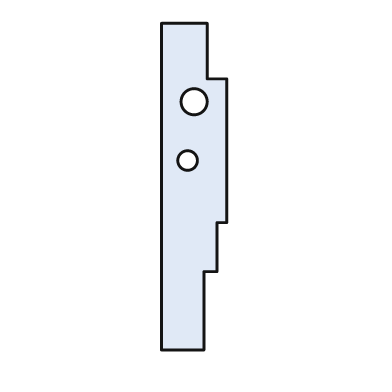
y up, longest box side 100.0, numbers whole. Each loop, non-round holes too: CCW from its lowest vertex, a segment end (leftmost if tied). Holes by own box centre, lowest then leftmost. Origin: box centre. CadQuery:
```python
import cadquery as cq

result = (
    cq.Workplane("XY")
    .moveTo(-10.0, -50.0)
    .lineTo(3.0, -50.0)
    .lineTo(3.0, -26.0)
    .lineTo(7.0, -26.0)
    .lineTo(7.0, -11.0)
    .lineTo(10.0, -11.0)
    .lineTo(10.0, 33.0)
    .lineTo(4.0, 33.0)
    .lineTo(4.0, 50.0)
    .lineTo(-10.0, 50.0)
    .close()
    .moveTo(-2.0, 8.0)
    .circle(3.0)
    .moveTo(0.0, 26.0)
    .circle(4.0)
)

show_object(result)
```